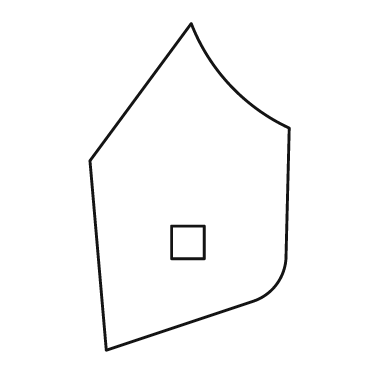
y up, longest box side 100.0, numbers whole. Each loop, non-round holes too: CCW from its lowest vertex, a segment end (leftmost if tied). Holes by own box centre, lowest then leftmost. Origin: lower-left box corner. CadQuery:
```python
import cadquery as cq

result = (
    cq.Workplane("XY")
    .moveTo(5.0, 0.0)
    .lineTo(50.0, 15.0)
    .threePointArc((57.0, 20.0), (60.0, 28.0))
    .lineTo(61.0, 68.0)
    .threePointArc((43.0, 81.0), (31.0, 100.0))
    .lineTo(0.0, 58.0)
    .close()
    .moveTo(25.0, 28.0)
    .lineTo(35.0, 28.0)
    .lineTo(35.0, 38.0)
    .lineTo(25.0, 38.0)
    .close()
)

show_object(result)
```